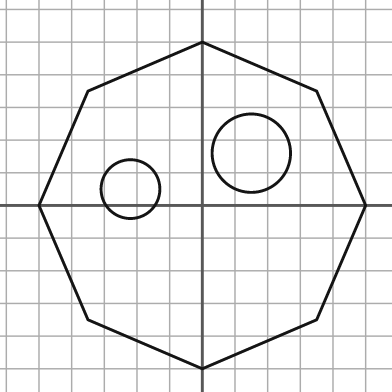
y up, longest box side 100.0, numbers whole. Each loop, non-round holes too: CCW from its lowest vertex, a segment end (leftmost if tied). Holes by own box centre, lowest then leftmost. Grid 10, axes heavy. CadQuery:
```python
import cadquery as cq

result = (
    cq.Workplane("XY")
    .moveTo(0.0, -50.0)
    .lineTo(35.0, -35.0)
    .lineTo(50.0, 0.0)
    .lineTo(35.0, 35.0)
    .lineTo(0.0, 50.0)
    .lineTo(-35.0, 35.0)
    .lineTo(-50.0, 0.0)
    .lineTo(-35.0, -35.0)
    .close()
    .moveTo(-22.0, 5.0)
    .circle(9.0)
    .moveTo(15.0, 16.0)
    .circle(12.0)
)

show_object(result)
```